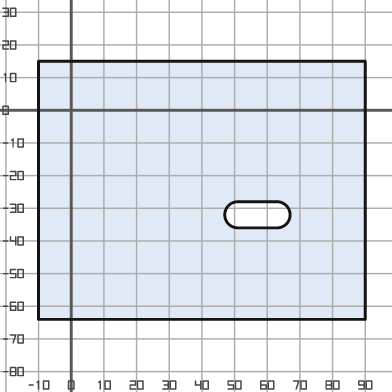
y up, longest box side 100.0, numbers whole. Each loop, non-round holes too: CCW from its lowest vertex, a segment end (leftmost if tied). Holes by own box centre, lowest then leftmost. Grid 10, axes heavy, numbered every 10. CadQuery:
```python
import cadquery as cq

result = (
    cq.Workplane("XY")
    .moveTo(-10.0, -64.0)
    .lineTo(90.0, -64.0)
    .lineTo(90.0, 15.0)
    .lineTo(-10.0, 15.0)
    .close()
    .moveTo(51.0, -36.0)
    .lineTo(63.0, -36.0)
    .threePointArc((67.0, -32.0), (63.0, -28.0))
    .lineTo(51.0, -28.0)
    .threePointArc((47.0, -32.0), (51.0, -36.0))
    .close()
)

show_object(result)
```